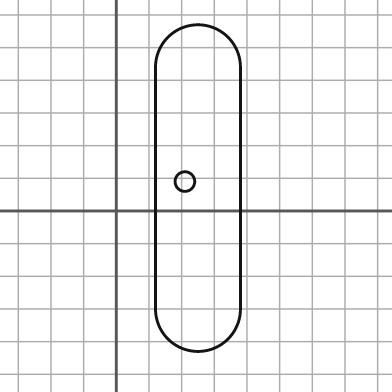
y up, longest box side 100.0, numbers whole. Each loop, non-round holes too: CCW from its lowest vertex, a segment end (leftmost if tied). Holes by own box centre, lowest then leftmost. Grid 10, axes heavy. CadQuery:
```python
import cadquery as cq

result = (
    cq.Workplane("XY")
    .moveTo(12.0, -30.0)
    .threePointArc((25.0, -43.0), (38.0, -30.0))
    .lineTo(38.0, 44.0)
    .threePointArc((25.0, 57.0), (12.0, 44.0))
    .close()
    .moveTo(21.0, 9.0)
    .circle(3.0)
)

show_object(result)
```